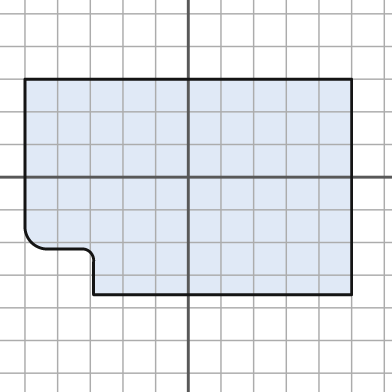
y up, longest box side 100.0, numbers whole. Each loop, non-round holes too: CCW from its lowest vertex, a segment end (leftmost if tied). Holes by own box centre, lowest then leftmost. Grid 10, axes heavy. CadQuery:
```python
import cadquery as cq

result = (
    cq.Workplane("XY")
    .moveTo(-29.0, -36.0)
    .lineTo(50.0, -36.0)
    .lineTo(50.0, 30.0)
    .lineTo(-50.0, 30.0)
    .lineTo(-50.0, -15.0)
    .threePointArc((-48.0, -20.0), (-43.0, -22.0))
    .lineTo(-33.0, -22.0)
    .threePointArc((-30.0, -23.0), (-29.0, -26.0))
    .close()
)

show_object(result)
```